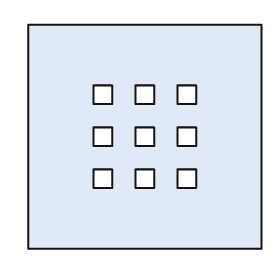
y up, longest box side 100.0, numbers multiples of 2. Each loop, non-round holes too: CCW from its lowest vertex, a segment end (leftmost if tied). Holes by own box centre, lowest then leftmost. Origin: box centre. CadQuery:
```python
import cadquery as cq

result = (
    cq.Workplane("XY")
    .moveTo(-50.0, -48.0)
    .lineTo(50.0, -48.0)
    .lineTo(50.0, 48.0)
    .lineTo(-50.0, 48.0)
    .close()
    .moveTo(-22.0, -22.0)
    .lineTo(-14.0, -22.0)
    .lineTo(-14.0, -14.0)
    .lineTo(-22.0, -14.0)
    .close()
    .moveTo(-4.0, -22.0)
    .lineTo(4.0, -22.0)
    .lineTo(4.0, -14.0)
    .lineTo(-4.0, -14.0)
    .close()
    .moveTo(14.0, -22.0)
    .lineTo(22.0, -22.0)
    .lineTo(22.0, -14.0)
    .lineTo(14.0, -14.0)
    .close()
    .moveTo(-22.0, -4.0)
    .lineTo(-14.0, -4.0)
    .lineTo(-14.0, 4.0)
    .lineTo(-22.0, 4.0)
    .close()
    .moveTo(-4.0, -4.0)
    .lineTo(4.0, -4.0)
    .lineTo(4.0, 4.0)
    .lineTo(-4.0, 4.0)
    .close()
    .moveTo(14.0, -4.0)
    .lineTo(22.0, -4.0)
    .lineTo(22.0, 4.0)
    .lineTo(14.0, 4.0)
    .close()
    .moveTo(-22.0, 14.0)
    .lineTo(-14.0, 14.0)
    .lineTo(-14.0, 22.0)
    .lineTo(-22.0, 22.0)
    .close()
    .moveTo(-4.0, 14.0)
    .lineTo(4.0, 14.0)
    .lineTo(4.0, 22.0)
    .lineTo(-4.0, 22.0)
    .close()
    .moveTo(14.0, 14.0)
    .lineTo(22.0, 14.0)
    .lineTo(22.0, 22.0)
    .lineTo(14.0, 22.0)
    .close()
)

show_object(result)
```